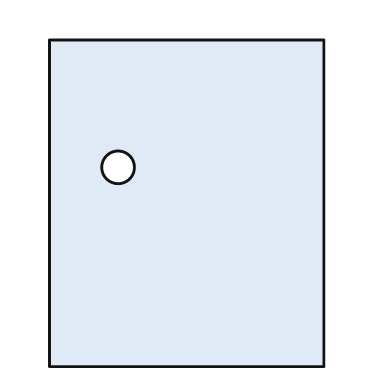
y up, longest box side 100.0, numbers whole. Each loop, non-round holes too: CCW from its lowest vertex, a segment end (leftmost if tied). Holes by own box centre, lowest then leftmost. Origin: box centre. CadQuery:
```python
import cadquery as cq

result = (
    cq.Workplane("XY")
    .moveTo(-42.0, -50.0)
    .lineTo(42.0, -50.0)
    .lineTo(42.0, 50.0)
    .lineTo(-42.0, 50.0)
    .close()
    .moveTo(-21.0, 11.0)
    .circle(5.0)
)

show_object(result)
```